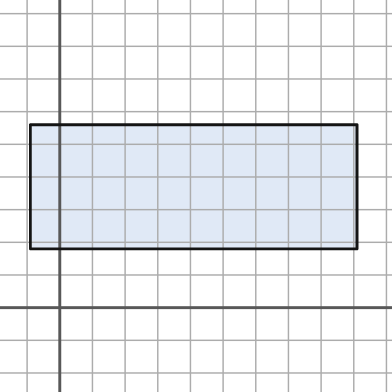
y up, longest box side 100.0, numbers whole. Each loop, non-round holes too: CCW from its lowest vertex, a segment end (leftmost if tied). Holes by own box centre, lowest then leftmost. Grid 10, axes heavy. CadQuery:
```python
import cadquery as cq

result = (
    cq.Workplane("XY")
    .moveTo(-9.0, 18.0)
    .lineTo(91.0, 18.0)
    .lineTo(91.0, 56.0)
    .lineTo(-9.0, 56.0)
    .close()
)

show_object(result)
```